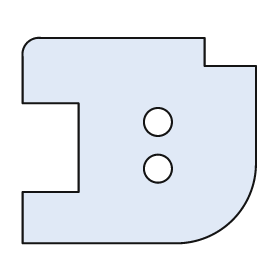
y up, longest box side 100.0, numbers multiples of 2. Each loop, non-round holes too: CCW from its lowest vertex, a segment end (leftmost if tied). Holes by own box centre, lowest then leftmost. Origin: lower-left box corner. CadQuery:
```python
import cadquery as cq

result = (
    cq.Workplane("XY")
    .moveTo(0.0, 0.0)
    .lineTo(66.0, 0.0)
    .threePointArc((90.0, 10.0), (100.0, 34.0))
    .lineTo(100.0, 76.0)
    .lineTo(78.0, 76.0)
    .lineTo(78.0, 88.0)
    .lineTo(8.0, 88.0)
    .threePointArc((2.0, 86.0), (0.0, 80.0))
    .lineTo(0.0, 60.0)
    .lineTo(24.0, 60.0)
    .lineTo(24.0, 22.0)
    .lineTo(0.0, 22.0)
    .close()
    .moveTo(58.0, 32.0)
    .circle(6.0)
    .moveTo(58.0, 52.0)
    .circle(6.0)
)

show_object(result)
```